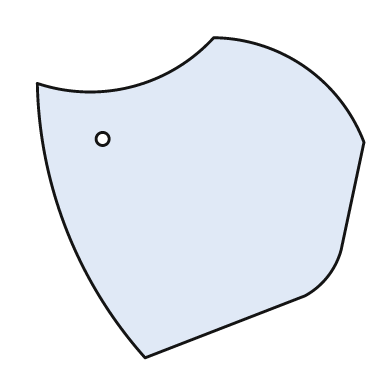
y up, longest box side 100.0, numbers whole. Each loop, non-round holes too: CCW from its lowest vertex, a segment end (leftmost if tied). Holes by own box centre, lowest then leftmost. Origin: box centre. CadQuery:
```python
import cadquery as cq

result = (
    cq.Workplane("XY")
    .moveTo(-17.0, -49.0)
    .lineTo(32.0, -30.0)
    .threePointArc((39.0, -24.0), (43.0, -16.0))
    .lineTo(50.0, 17.0)
    .threePointArc((32.0, 40.0), (4.0, 49.0))
    .threePointArc((-21.0, 34.0), (-50.0, 35.0))
    .threePointArc((-41.0, -10.0), (-17.0, -49.0))
    .close()
    .moveTo(-30.0, 18.0)
    .circle(2.0)
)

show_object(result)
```